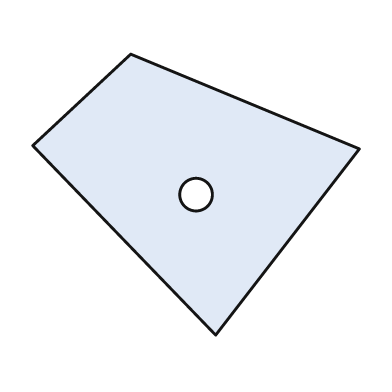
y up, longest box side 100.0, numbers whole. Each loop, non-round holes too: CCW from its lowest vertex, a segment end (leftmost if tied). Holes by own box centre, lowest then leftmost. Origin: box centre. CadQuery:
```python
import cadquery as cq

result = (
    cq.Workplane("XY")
    .moveTo(6.0, -43.0)
    .lineTo(50.0, 14.0)
    .lineTo(-20.0, 43.0)
    .lineTo(-50.0, 15.0)
    .close()
    .moveTo(0.0, 0.0)
    .circle(5.0)
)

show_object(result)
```